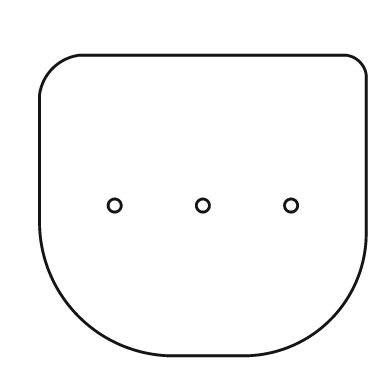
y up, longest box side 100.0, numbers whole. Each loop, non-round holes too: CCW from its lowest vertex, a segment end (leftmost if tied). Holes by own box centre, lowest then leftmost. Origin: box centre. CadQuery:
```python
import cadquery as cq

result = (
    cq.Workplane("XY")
    .moveTo(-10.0, -46.0)
    .lineTo(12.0, -46.0)
    .threePointArc((39.0, -35.0), (50.0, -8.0))
    .lineTo(50.0, 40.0)
    .threePointArc((48.0, 44.0), (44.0, 46.0))
    .lineTo(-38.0, 46.0)
    .threePointArc((-46.0, 42.0), (-50.0, 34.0))
    .lineTo(-50.0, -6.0)
    .threePointArc((-38.0, -34.0), (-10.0, -46.0))
    .close()
    .moveTo(-27.0, 0.0)
    .circle(2.0)
    .moveTo(0.0, 0.0)
    .circle(2.0)
    .moveTo(27.0, 0.0)
    .circle(2.0)
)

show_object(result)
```